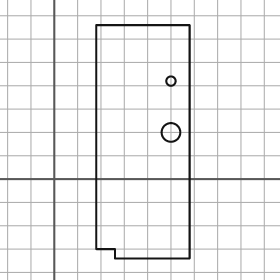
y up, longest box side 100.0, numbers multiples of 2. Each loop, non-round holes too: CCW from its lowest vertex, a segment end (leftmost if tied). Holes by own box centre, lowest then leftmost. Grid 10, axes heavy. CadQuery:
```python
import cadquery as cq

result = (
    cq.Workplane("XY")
    .moveTo(26.0, -34.0)
    .lineTo(58.0, -34.0)
    .lineTo(58.0, 66.0)
    .lineTo(18.0, 66.0)
    .lineTo(18.0, -30.0)
    .lineTo(26.0, -30.0)
    .close()
    .moveTo(50.0, 20.0)
    .circle(4.0)
    .moveTo(50.0, 42.0)
    .circle(2.0)
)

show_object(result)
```